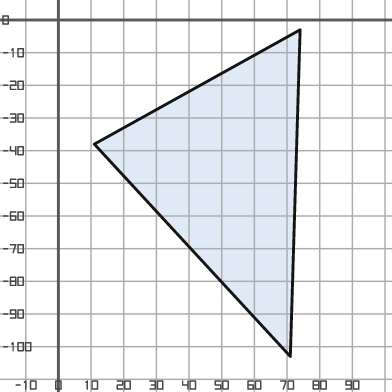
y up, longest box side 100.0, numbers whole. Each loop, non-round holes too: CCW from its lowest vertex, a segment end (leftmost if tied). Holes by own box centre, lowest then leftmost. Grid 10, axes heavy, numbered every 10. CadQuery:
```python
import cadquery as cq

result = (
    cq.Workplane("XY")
    .moveTo(71.0, -103.0)
    .lineTo(74.0, -3.0)
    .lineTo(11.0, -38.0)
    .close()
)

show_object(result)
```